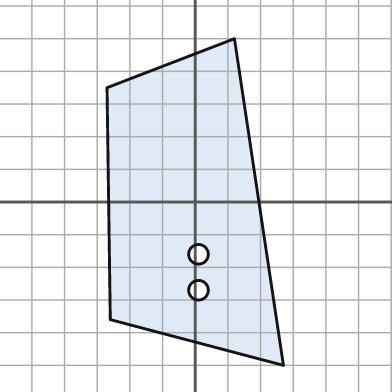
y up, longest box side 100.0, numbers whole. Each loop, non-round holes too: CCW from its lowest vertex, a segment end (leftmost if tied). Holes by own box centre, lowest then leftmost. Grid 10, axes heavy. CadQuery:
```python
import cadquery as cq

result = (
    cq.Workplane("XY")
    .moveTo(27.0, -50.0)
    .lineTo(12.0, 50.0)
    .lineTo(-27.0, 35.0)
    .lineTo(-26.0, -36.0)
    .close()
    .moveTo(1.0, -27.0)
    .circle(3.0)
    .moveTo(1.0, -16.0)
    .circle(3.0)
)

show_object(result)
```